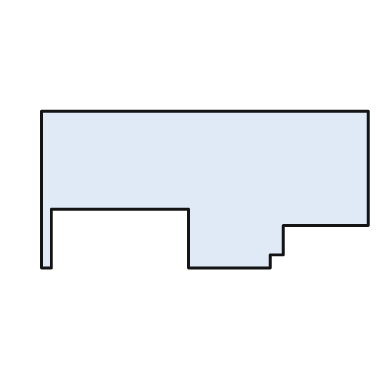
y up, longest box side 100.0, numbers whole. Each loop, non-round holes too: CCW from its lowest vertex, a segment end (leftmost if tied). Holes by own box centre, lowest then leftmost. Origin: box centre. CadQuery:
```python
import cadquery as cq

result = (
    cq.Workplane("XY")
    .moveTo(-50.0, -24.0)
    .lineTo(-47.0, -24.0)
    .lineTo(-47.0, -6.0)
    .lineTo(-5.0, -6.0)
    .lineTo(-5.0, -24.0)
    .lineTo(20.0, -24.0)
    .lineTo(20.0, -20.0)
    .lineTo(24.0, -20.0)
    .lineTo(24.0, -11.0)
    .lineTo(50.0, -11.0)
    .lineTo(50.0, 24.0)
    .lineTo(-50.0, 24.0)
    .close()
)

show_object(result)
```